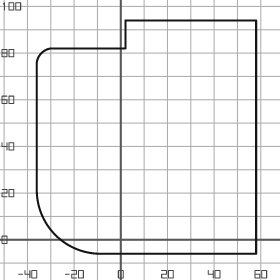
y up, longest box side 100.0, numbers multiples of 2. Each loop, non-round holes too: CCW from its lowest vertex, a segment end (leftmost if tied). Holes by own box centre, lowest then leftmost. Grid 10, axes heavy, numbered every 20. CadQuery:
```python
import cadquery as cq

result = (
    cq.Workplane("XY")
    .moveTo(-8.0, -6.0)
    .lineTo(58.0, -6.0)
    .lineTo(58.0, 94.0)
    .lineTo(2.0, 94.0)
    .lineTo(2.0, 82.0)
    .lineTo(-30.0, 82.0)
    .threePointArc((-34.0, 80.0), (-36.0, 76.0))
    .lineTo(-36.0, 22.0)
    .threePointArc((-28.0, 2.0), (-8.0, -6.0))
    .close()
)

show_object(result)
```